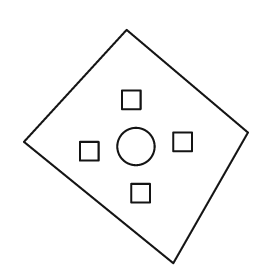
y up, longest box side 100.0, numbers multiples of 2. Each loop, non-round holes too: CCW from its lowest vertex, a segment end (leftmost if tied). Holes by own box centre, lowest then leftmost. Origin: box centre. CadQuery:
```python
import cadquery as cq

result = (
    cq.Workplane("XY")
    .moveTo(16.0, -50.0)
    .lineTo(48.0, 6.0)
    .lineTo(-4.0, 50.0)
    .lineTo(-48.0, 2.0)
    .close()
    .moveTo(-2.0, -24.0)
    .lineTo(6.0, -24.0)
    .lineTo(6.0, -16.0)
    .lineTo(-2.0, -16.0)
    .close()
    .moveTo(-24.0, -6.0)
    .lineTo(-16.0, -6.0)
    .lineTo(-16.0, 2.0)
    .lineTo(-24.0, 2.0)
    .close()
    .moveTo(0.0, 0.0)
    .circle(8.0)
    .moveTo(16.0, -2.0)
    .lineTo(24.0, -2.0)
    .lineTo(24.0, 6.0)
    .lineTo(16.0, 6.0)
    .close()
    .moveTo(-6.0, 16.0)
    .lineTo(2.0, 16.0)
    .lineTo(2.0, 24.0)
    .lineTo(-6.0, 24.0)
    .close()
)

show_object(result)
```